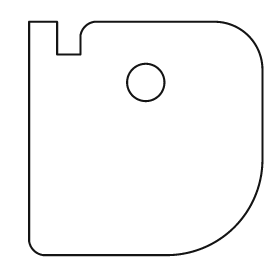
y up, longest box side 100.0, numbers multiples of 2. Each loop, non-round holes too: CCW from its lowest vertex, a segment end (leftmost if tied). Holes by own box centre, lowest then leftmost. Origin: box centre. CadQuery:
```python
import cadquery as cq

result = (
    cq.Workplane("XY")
    .moveTo(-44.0, -50.0)
    .lineTo(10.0, -50.0)
    .threePointArc((38.0, -38.0), (50.0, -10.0))
    .lineTo(50.0, 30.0)
    .threePointArc((44.0, 44.0), (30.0, 50.0))
    .lineTo(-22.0, 50.0)
    .threePointArc((-26.0, 48.0), (-28.0, 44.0))
    .lineTo(-28.0, 36.0)
    .lineTo(-38.0, 36.0)
    .lineTo(-38.0, 50.0)
    .lineTo(-50.0, 50.0)
    .lineTo(-50.0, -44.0)
    .threePointArc((-48.0, -48.0), (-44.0, -50.0))
    .close()
    .moveTo(0.0, 24.0)
    .circle(8.0)
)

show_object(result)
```